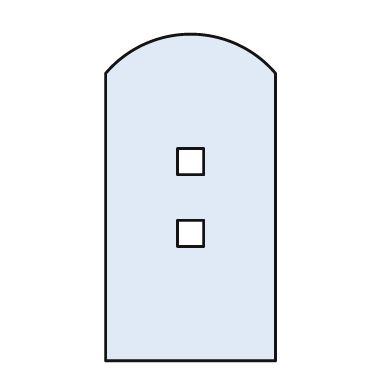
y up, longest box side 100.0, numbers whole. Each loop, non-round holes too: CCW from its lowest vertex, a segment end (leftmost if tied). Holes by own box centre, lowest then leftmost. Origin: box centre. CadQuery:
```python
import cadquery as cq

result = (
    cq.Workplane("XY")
    .moveTo(-26.0, -50.0)
    .lineTo(26.0, -50.0)
    .lineTo(26.0, 38.0)
    .threePointArc((0.0, 50.0), (-26.0, 38.0))
    .close()
    .moveTo(-4.0, -15.0)
    .lineTo(4.0, -15.0)
    .lineTo(4.0, -7.0)
    .lineTo(-4.0, -7.0)
    .close()
    .moveTo(-4.0, 7.0)
    .lineTo(4.0, 7.0)
    .lineTo(4.0, 15.0)
    .lineTo(-4.0, 15.0)
    .close()
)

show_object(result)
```